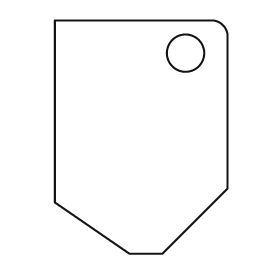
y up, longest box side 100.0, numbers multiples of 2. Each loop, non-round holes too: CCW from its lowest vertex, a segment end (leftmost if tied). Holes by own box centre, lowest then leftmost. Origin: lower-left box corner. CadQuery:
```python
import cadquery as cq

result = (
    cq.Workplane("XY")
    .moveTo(32.0, 0.0)
    .lineTo(46.0, 0.0)
    .lineTo(74.0, 28.0)
    .lineTo(74.0, 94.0)
    .threePointArc((72.0, 98.0), (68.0, 100.0))
    .lineTo(0.0, 100.0)
    .lineTo(0.0, 22.0)
    .close()
    .moveTo(56.0, 86.0)
    .circle(8.0)
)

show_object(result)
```